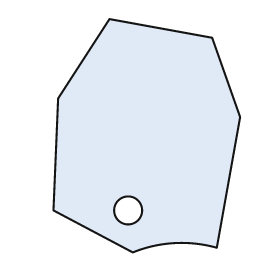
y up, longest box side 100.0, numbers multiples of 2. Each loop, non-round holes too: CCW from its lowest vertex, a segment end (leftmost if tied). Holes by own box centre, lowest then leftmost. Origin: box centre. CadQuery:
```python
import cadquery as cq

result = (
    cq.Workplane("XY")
    .moveTo(-6.0, -50.0)
    .threePointArc((12.0, -46.0), (30.0, -48.0))
    .lineTo(40.0, 8.0)
    .lineTo(28.0, 42.0)
    .lineTo(-16.0, 50.0)
    .lineTo(-38.0, 16.0)
    .lineTo(-40.0, -32.0)
    .close()
    .moveTo(-8.0, -32.0)
    .circle(6.0)
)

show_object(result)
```